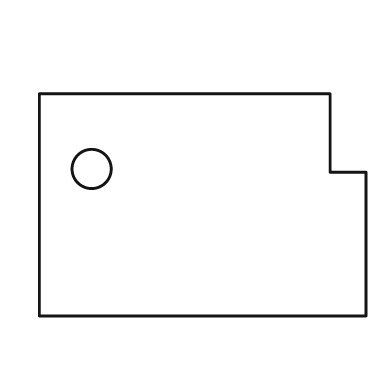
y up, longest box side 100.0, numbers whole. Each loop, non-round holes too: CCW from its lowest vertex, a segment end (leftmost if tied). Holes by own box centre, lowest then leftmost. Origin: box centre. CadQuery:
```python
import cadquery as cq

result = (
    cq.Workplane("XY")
    .moveTo(-50.0, -34.0)
    .lineTo(50.0, -34.0)
    .lineTo(50.0, 10.0)
    .lineTo(39.0, 10.0)
    .lineTo(39.0, 34.0)
    .lineTo(-50.0, 34.0)
    .close()
    .moveTo(-34.0, 11.0)
    .circle(6.0)
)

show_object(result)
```